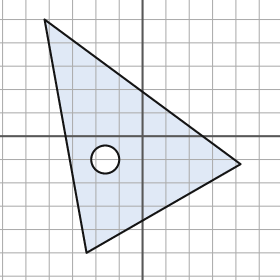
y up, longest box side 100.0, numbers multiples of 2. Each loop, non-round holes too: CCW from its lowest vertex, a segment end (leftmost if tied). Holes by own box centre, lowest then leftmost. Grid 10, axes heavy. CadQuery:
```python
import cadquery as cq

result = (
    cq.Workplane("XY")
    .moveTo(-24.0, -50.0)
    .lineTo(42.0, -12.0)
    .lineTo(-42.0, 50.0)
    .close()
    .moveTo(-16.0, -10.0)
    .circle(6.0)
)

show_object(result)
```